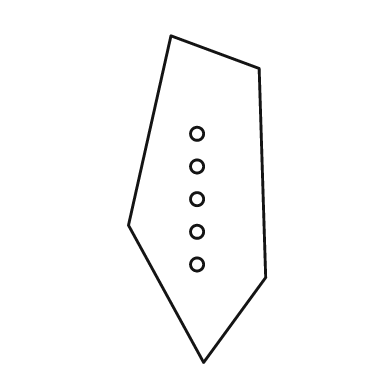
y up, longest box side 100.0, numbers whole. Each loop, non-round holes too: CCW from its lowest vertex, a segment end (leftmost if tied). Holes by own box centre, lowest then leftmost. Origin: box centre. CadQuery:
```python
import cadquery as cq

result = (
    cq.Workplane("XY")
    .moveTo(2.0, -50.0)
    .lineTo(21.0, -24.0)
    .lineTo(19.0, 40.0)
    .lineTo(-8.0, 50.0)
    .lineTo(-21.0, -8.0)
    .close()
    .moveTo(0.0, -20.0)
    .circle(2.0)
    .moveTo(0.0, -10.0)
    .circle(2.0)
    .moveTo(0.0, 0.0)
    .circle(2.0)
    .moveTo(0.0, 10.0)
    .circle(2.0)
    .moveTo(0.0, 20.0)
    .circle(2.0)
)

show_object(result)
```